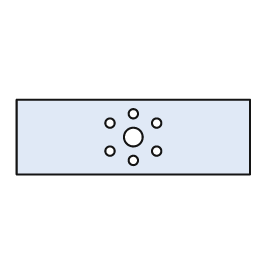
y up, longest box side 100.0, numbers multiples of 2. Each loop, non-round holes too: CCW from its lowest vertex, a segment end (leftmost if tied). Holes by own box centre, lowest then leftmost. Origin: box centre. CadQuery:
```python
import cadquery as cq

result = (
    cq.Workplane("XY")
    .moveTo(-50.0, -16.0)
    .lineTo(50.0, -16.0)
    .lineTo(50.0, 16.0)
    .lineTo(-50.0, 16.0)
    .close()
    .moveTo(0.0, -10.0)
    .circle(2.0)
    .moveTo(-10.0, -6.0)
    .circle(2.0)
    .moveTo(10.0, -6.0)
    .circle(2.0)
    .moveTo(0.0, 0.0)
    .circle(4.0)
    .moveTo(-10.0, 6.0)
    .circle(2.0)
    .moveTo(10.0, 6.0)
    .circle(2.0)
    .moveTo(0.0, 10.0)
    .circle(2.0)
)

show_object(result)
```